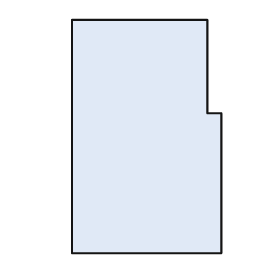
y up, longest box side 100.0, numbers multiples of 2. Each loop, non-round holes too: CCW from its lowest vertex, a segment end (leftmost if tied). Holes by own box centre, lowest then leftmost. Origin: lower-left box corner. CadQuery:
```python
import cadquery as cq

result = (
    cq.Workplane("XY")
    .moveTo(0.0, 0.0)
    .lineTo(64.0, 0.0)
    .lineTo(64.0, 60.0)
    .lineTo(58.0, 60.0)
    .lineTo(58.0, 100.0)
    .lineTo(0.0, 100.0)
    .close()
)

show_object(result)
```